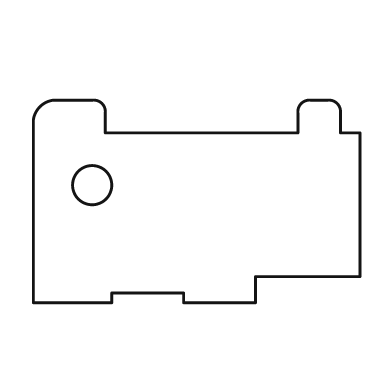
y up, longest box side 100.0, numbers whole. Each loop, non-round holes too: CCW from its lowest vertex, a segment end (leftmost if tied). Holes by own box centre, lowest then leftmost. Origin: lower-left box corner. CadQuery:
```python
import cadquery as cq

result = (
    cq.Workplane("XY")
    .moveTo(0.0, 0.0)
    .lineTo(24.0, 0.0)
    .lineTo(24.0, 3.0)
    .lineTo(46.0, 3.0)
    .lineTo(46.0, 0.0)
    .lineTo(68.0, 0.0)
    .lineTo(68.0, 8.0)
    .lineTo(100.0, 8.0)
    .lineTo(100.0, 52.0)
    .lineTo(94.0, 52.0)
    .lineTo(94.0, 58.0)
    .threePointArc((93.0, 61.0), (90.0, 62.0))
    .lineTo(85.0, 62.0)
    .threePointArc((82.0, 61.0), (81.0, 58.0))
    .lineTo(81.0, 52.0)
    .lineTo(22.0, 52.0)
    .lineTo(22.0, 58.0)
    .threePointArc((21.0, 61.0), (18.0, 62.0))
    .lineTo(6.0, 62.0)
    .threePointArc((2.0, 60.0), (0.0, 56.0))
    .close()
    .moveTo(18.0, 36.0)
    .circle(6.0)
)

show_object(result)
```